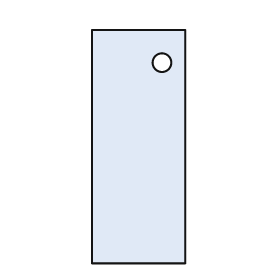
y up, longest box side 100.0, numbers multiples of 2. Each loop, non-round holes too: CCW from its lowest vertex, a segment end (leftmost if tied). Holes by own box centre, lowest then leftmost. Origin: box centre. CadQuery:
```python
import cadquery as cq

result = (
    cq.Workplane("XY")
    .moveTo(-20.0, -50.0)
    .lineTo(20.0, -50.0)
    .lineTo(20.0, 50.0)
    .lineTo(-20.0, 50.0)
    .close()
    .moveTo(10.0, 36.0)
    .circle(4.0)
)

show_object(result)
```